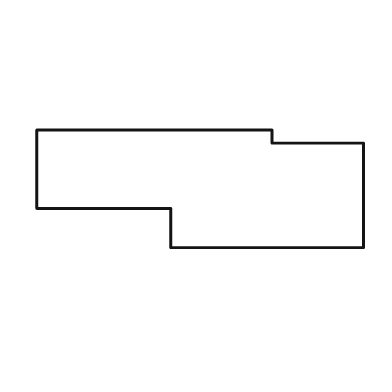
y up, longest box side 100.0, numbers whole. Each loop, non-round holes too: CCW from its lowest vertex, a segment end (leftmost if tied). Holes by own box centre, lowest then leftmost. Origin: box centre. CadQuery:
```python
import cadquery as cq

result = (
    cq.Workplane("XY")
    .moveTo(-9.0, -18.0)
    .lineTo(50.0, -18.0)
    .lineTo(50.0, 14.0)
    .lineTo(22.0, 14.0)
    .lineTo(22.0, 18.0)
    .lineTo(-50.0, 18.0)
    .lineTo(-50.0, -6.0)
    .lineTo(-9.0, -6.0)
    .close()
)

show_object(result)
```